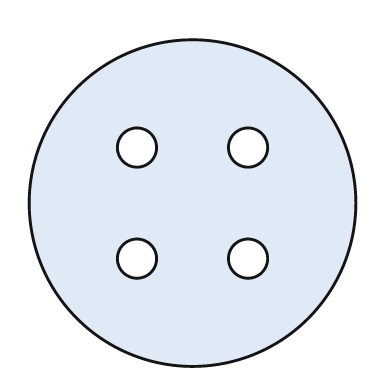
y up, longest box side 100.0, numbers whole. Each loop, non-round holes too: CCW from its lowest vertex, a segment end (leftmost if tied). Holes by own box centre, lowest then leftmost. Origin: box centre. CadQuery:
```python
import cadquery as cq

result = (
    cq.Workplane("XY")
    .moveTo(0.0, 0.0)
    .circle(50.0)
    .moveTo(-17.0, -17.0)
    .circle(6.0)
    .moveTo(17.0, -17.0)
    .circle(6.0)
    .moveTo(-17.0, 17.0)
    .circle(6.0)
    .moveTo(17.0, 17.0)
    .circle(6.0)
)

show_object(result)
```